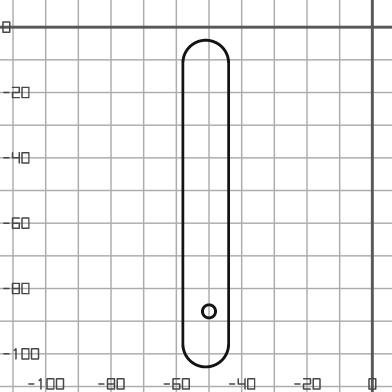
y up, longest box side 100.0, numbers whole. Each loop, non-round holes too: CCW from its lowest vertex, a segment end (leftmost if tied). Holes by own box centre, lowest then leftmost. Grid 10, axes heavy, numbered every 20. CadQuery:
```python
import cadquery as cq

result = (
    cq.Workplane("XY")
    .moveTo(-58.0, -97.0)
    .threePointArc((-51.0, -104.0), (-44.0, -97.0))
    .lineTo(-44.0, -11.0)
    .threePointArc((-51.0, -4.0), (-58.0, -11.0))
    .close()
    .moveTo(-50.0, -87.0)
    .circle(2.0)
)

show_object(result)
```